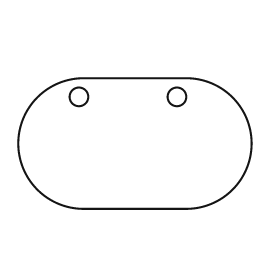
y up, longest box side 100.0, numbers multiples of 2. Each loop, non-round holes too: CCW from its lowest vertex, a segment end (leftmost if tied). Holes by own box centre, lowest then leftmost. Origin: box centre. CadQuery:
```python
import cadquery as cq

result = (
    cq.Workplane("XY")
    .moveTo(-22.0, -28.0)
    .lineTo(22.0, -28.0)
    .threePointArc((50.0, 0.0), (22.0, 28.0))
    .lineTo(-22.0, 28.0)
    .threePointArc((-50.0, 0.0), (-22.0, -28.0))
    .close()
    .moveTo(-24.0, 20.0)
    .circle(4.0)
    .moveTo(18.0, 20.0)
    .circle(4.0)
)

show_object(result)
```